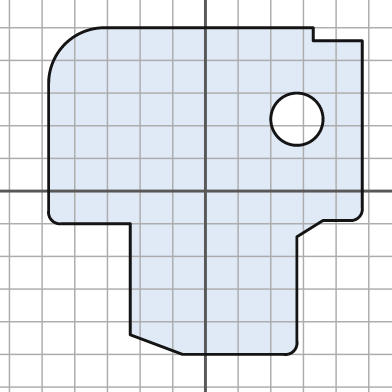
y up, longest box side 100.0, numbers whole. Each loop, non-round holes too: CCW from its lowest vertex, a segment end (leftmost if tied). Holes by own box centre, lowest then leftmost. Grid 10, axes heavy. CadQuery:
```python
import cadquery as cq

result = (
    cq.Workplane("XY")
    .moveTo(-7.0, -50.0)
    .lineTo(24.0, -50.0)
    .threePointArc((27.0, -49.0), (28.0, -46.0))
    .lineTo(28.0, -14.0)
    .lineTo(36.0, -9.0)
    .lineTo(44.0, -9.0)
    .threePointArc((47.0, -8.0), (48.0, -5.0))
    .lineTo(48.0, 46.0)
    .lineTo(33.0, 46.0)
    .lineTo(33.0, 50.0)
    .lineTo(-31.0, 50.0)
    .threePointArc((-43.0, 45.0), (-48.0, 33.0))
    .lineTo(-48.0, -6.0)
    .threePointArc((-47.0, -9.0), (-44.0, -10.0))
    .lineTo(-23.0, -10.0)
    .lineTo(-23.0, -44.0)
    .close()
    .moveTo(28.0, 22.0)
    .circle(8.0)
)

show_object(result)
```